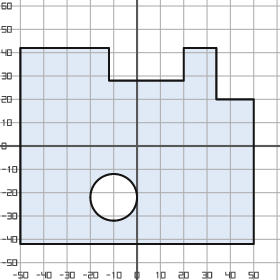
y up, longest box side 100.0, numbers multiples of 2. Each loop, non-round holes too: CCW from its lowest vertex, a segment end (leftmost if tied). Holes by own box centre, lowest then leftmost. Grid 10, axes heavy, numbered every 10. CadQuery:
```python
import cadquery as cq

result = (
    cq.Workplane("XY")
    .moveTo(-50.0, -42.0)
    .lineTo(50.0, -42.0)
    .lineTo(50.0, 20.0)
    .lineTo(34.0, 20.0)
    .lineTo(34.0, 42.0)
    .lineTo(20.0, 42.0)
    .lineTo(20.0, 28.0)
    .lineTo(-12.0, 28.0)
    .lineTo(-12.0, 42.0)
    .lineTo(-50.0, 42.0)
    .close()
    .moveTo(-10.0, -22.0)
    .circle(10.0)
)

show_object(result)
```